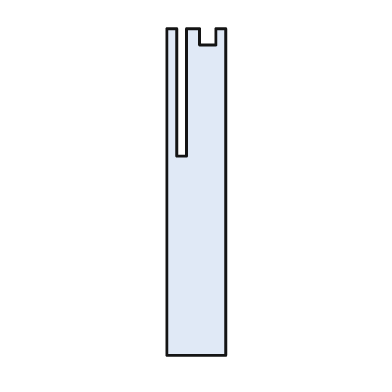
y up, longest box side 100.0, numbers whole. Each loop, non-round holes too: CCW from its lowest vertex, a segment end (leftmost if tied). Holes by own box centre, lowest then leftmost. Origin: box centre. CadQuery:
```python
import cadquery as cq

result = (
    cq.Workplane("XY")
    .moveTo(-9.0, -50.0)
    .lineTo(9.0, -50.0)
    .lineTo(9.0, 50.0)
    .lineTo(6.0, 50.0)
    .lineTo(6.0, 45.0)
    .lineTo(1.0, 45.0)
    .lineTo(1.0, 50.0)
    .lineTo(-3.0, 50.0)
    .lineTo(-3.0, 11.0)
    .lineTo(-6.0, 11.0)
    .lineTo(-6.0, 50.0)
    .lineTo(-9.0, 50.0)
    .close()
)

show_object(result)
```